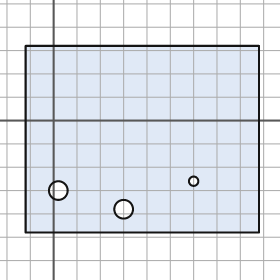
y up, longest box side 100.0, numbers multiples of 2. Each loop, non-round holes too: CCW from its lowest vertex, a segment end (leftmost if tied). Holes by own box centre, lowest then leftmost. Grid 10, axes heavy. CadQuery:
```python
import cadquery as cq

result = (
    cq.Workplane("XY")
    .moveTo(-12.0, -48.0)
    .lineTo(88.0, -48.0)
    .lineTo(88.0, 32.0)
    .lineTo(-12.0, 32.0)
    .close()
    .moveTo(30.0, -38.0)
    .circle(4.0)
    .moveTo(2.0, -30.0)
    .circle(4.0)
    .moveTo(60.0, -26.0)
    .circle(2.0)
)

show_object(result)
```